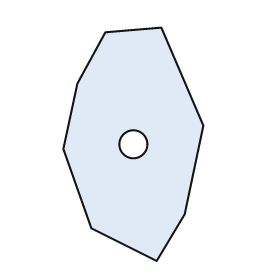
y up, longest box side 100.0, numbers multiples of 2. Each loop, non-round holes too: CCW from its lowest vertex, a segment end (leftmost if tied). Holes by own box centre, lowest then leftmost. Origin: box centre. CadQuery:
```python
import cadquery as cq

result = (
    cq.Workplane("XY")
    .moveTo(10.0, -50.0)
    .lineTo(22.0, -30.0)
    .lineTo(30.0, 8.0)
    .lineTo(12.0, 50.0)
    .lineTo(-12.0, 48.0)
    .lineTo(-24.0, 26.0)
    .lineTo(-30.0, -2.0)
    .lineTo(-18.0, -36.0)
    .close()
    .moveTo(0.0, 0.0)
    .circle(6.0)
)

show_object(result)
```